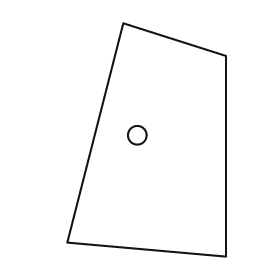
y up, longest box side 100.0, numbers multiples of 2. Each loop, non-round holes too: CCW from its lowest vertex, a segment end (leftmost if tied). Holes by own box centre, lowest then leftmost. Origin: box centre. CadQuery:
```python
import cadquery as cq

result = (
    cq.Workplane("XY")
    .moveTo(34.0, -50.0)
    .lineTo(34.0, 36.0)
    .lineTo(-10.0, 50.0)
    .lineTo(-34.0, -44.0)
    .close()
    .moveTo(-4.0, 2.0)
    .circle(4.0)
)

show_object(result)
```